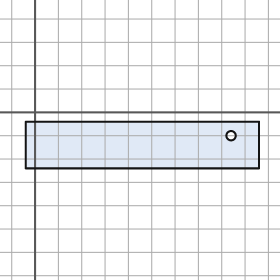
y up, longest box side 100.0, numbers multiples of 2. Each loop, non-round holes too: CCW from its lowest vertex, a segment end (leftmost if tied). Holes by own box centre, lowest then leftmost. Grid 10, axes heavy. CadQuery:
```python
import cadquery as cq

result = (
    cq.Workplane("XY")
    .moveTo(-4.0, -24.0)
    .lineTo(96.0, -24.0)
    .lineTo(96.0, -4.0)
    .lineTo(-4.0, -4.0)
    .close()
    .moveTo(84.0, -10.0)
    .circle(2.0)
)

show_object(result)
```